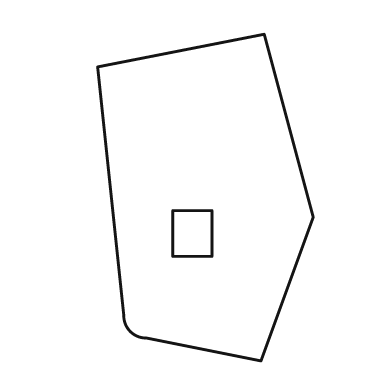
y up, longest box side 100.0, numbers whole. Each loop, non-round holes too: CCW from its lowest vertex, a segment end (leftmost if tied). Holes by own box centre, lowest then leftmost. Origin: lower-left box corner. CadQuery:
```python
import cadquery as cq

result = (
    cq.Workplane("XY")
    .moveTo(50.0, 0.0)
    .lineTo(66.0, 44.0)
    .lineTo(51.0, 100.0)
    .lineTo(0.0, 90.0)
    .lineTo(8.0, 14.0)
    .threePointArc((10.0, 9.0), (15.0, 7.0))
    .close()
    .moveTo(23.0, 32.0)
    .lineTo(35.0, 32.0)
    .lineTo(35.0, 46.0)
    .lineTo(23.0, 46.0)
    .close()
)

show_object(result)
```